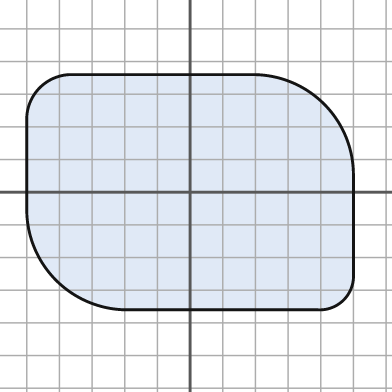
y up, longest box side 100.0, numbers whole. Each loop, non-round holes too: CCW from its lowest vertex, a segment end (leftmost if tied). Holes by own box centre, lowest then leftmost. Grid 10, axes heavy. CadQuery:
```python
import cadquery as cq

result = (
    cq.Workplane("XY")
    .moveTo(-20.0, -36.0)
    .lineTo(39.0, -36.0)
    .threePointArc((47.0, -33.0), (50.0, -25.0))
    .lineTo(50.0, 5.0)
    .threePointArc((41.0, 27.0), (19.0, 36.0))
    .lineTo(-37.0, 36.0)
    .threePointArc((-46.0, 32.0), (-50.0, 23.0))
    .lineTo(-50.0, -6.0)
    .threePointArc((-41.0, -27.0), (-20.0, -36.0))
    .close()
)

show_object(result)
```